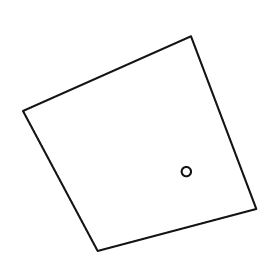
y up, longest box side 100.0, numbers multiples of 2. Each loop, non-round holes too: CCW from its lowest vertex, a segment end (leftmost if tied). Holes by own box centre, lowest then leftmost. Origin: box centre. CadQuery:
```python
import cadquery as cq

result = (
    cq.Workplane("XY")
    .moveTo(-18.0, -46.0)
    .lineTo(50.0, -28.0)
    .lineTo(22.0, 46.0)
    .lineTo(-50.0, 14.0)
    .close()
    .moveTo(20.0, -12.0)
    .circle(2.0)
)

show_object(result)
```